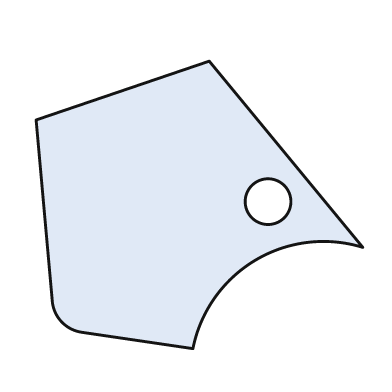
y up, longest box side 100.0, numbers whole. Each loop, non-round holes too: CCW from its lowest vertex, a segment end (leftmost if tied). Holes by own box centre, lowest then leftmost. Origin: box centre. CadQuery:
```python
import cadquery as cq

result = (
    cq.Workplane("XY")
    .moveTo(-2.0, -44.0)
    .threePointArc((17.0, -17.0), (50.0, -13.0))
    .lineTo(3.0, 44.0)
    .lineTo(-50.0, 26.0)
    .lineTo(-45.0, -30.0)
    .threePointArc((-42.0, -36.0), (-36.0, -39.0))
    .close()
    .moveTo(21.0, 1.0)
    .circle(7.0)
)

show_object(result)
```